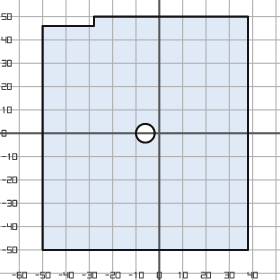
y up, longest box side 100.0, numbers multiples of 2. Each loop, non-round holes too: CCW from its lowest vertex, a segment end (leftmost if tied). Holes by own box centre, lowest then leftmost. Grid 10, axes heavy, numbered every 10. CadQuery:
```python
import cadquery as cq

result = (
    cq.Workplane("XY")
    .moveTo(-50.0, -50.0)
    .lineTo(38.0, -50.0)
    .lineTo(38.0, 50.0)
    .lineTo(-28.0, 50.0)
    .lineTo(-28.0, 46.0)
    .lineTo(-50.0, 46.0)
    .close()
    .moveTo(-6.0, 0.0)
    .circle(4.0)
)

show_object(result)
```